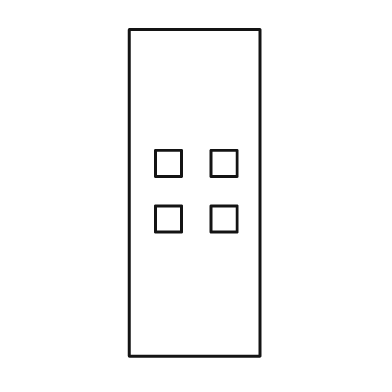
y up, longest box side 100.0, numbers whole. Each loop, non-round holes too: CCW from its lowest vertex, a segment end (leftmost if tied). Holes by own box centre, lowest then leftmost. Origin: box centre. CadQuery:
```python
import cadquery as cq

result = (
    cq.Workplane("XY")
    .moveTo(-20.0, -50.0)
    .lineTo(20.0, -50.0)
    .lineTo(20.0, 50.0)
    .lineTo(-20.0, 50.0)
    .close()
    .moveTo(-12.0, -12.0)
    .lineTo(-4.0, -12.0)
    .lineTo(-4.0, -4.0)
    .lineTo(-12.0, -4.0)
    .close()
    .moveTo(5.0, -12.0)
    .lineTo(13.0, -12.0)
    .lineTo(13.0, -4.0)
    .lineTo(5.0, -4.0)
    .close()
    .moveTo(-12.0, 5.0)
    .lineTo(-4.0, 5.0)
    .lineTo(-4.0, 13.0)
    .lineTo(-12.0, 13.0)
    .close()
    .moveTo(5.0, 5.0)
    .lineTo(13.0, 5.0)
    .lineTo(13.0, 13.0)
    .lineTo(5.0, 13.0)
    .close()
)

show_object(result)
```